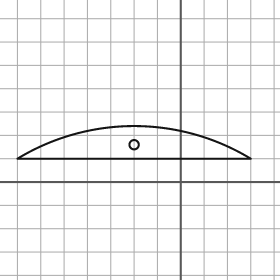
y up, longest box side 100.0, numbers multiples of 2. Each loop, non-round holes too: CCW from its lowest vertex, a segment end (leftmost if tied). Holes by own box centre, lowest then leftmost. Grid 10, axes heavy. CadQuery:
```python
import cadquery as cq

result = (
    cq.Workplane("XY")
    .moveTo(-70.0, 10.0)
    .lineTo(30.0, 10.0)
    .threePointArc((-20.0, 24.0), (-70.0, 10.0))
    .close()
    .moveTo(-20.0, 16.0)
    .circle(2.0)
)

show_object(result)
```